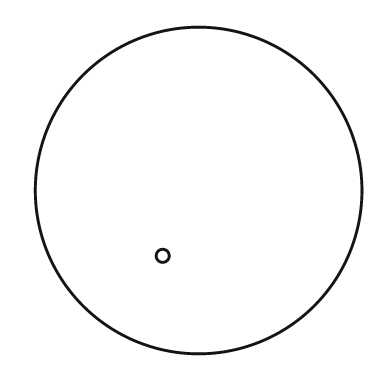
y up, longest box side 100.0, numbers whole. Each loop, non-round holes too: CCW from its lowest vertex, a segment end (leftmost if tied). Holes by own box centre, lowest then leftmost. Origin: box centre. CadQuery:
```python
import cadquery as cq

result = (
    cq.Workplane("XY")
    .moveTo(0.0, 0.0)
    .circle(50.0)
    .moveTo(-11.0, -20.0)
    .circle(2.0)
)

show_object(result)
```